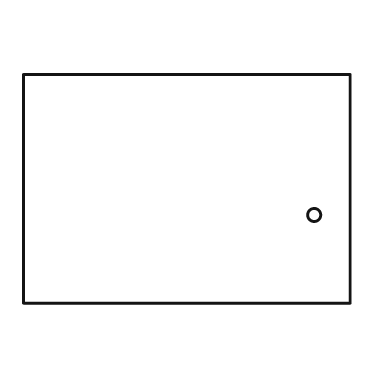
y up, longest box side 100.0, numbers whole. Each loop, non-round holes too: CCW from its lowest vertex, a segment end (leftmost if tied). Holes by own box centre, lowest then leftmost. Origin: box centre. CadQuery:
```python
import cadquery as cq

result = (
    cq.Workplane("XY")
    .moveTo(-50.0, -35.0)
    .lineTo(50.0, -35.0)
    .lineTo(50.0, 35.0)
    .lineTo(-50.0, 35.0)
    .close()
    .moveTo(39.0, -8.0)
    .circle(2.0)
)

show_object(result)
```